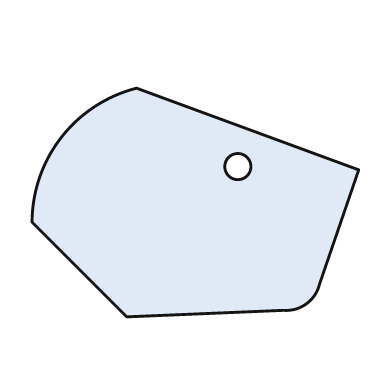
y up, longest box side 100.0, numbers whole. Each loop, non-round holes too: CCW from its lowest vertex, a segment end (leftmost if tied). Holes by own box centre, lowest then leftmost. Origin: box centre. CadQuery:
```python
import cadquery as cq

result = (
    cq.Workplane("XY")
    .moveTo(-21.0, -35.0)
    .lineTo(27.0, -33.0)
    .threePointArc((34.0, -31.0), (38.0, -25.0))
    .lineTo(50.0, 10.0)
    .lineTo(-18.0, 35.0)
    .threePointArc((-41.0, 20.0), (-50.0, -6.0))
    .close()
    .moveTo(13.0, 11.0)
    .circle(4.0)
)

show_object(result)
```